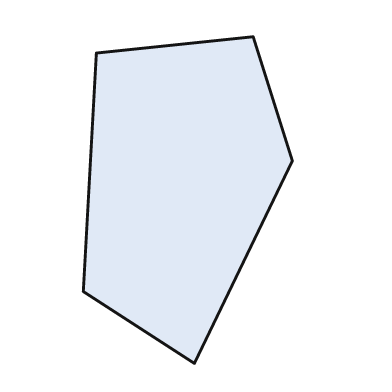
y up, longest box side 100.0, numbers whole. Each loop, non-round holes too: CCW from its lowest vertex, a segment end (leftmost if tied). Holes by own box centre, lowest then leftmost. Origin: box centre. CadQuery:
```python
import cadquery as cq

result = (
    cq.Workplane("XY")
    .moveTo(2.0, -50.0)
    .lineTo(32.0, 12.0)
    .lineTo(20.0, 50.0)
    .lineTo(-28.0, 45.0)
    .lineTo(-32.0, -28.0)
    .close()
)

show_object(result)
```